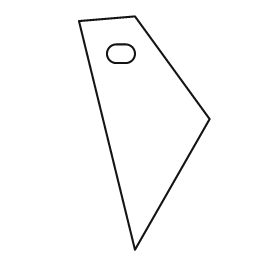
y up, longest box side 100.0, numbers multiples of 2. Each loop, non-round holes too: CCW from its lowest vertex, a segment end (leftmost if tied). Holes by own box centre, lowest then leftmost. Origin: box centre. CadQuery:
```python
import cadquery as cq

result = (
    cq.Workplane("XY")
    .moveTo(-4.0, -50.0)
    .lineTo(28.0, 6.0)
    .lineTo(-4.0, 50.0)
    .lineTo(-28.0, 48.0)
    .close()
    .moveTo(-12.0, 30.0)
    .lineTo(-8.0, 30.0)
    .threePointArc((-4.0, 34.0), (-8.0, 38.0))
    .lineTo(-12.0, 38.0)
    .threePointArc((-16.0, 34.0), (-12.0, 30.0))
    .close()
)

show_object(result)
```